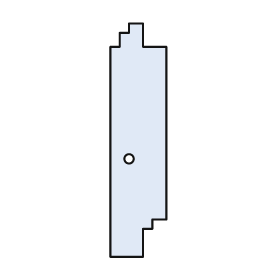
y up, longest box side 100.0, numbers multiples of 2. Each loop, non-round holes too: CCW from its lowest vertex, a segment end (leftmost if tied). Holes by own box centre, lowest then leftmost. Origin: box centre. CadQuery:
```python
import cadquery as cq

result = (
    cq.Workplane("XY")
    .moveTo(-12.0, -50.0)
    .lineTo(2.0, -50.0)
    .lineTo(2.0, -38.0)
    .lineTo(6.0, -38.0)
    .lineTo(6.0, -34.0)
    .lineTo(12.0, -34.0)
    .lineTo(12.0, 40.0)
    .lineTo(2.0, 40.0)
    .lineTo(2.0, 50.0)
    .lineTo(-4.0, 50.0)
    .lineTo(-4.0, 46.0)
    .lineTo(-8.0, 46.0)
    .lineTo(-8.0, 40.0)
    .lineTo(-12.0, 40.0)
    .close()
    .moveTo(-4.0, -8.0)
    .circle(2.0)
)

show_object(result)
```